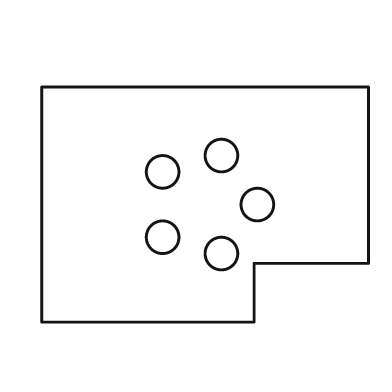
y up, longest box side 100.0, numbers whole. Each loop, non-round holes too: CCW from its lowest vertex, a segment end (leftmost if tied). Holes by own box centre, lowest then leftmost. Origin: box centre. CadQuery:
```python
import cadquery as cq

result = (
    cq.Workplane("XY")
    .moveTo(-50.0, -36.0)
    .lineTo(15.0, -36.0)
    .lineTo(15.0, -18.0)
    .lineTo(50.0, -18.0)
    .lineTo(50.0, 36.0)
    .lineTo(-50.0, 36.0)
    .close()
    .moveTo(5.0, -15.0)
    .circle(5.0)
    .moveTo(-13.0, -10.0)
    .circle(5.0)
    .moveTo(16.0, 0.0)
    .circle(5.0)
    .moveTo(-13.0, 10.0)
    .circle(5.0)
    .moveTo(5.0, 15.0)
    .circle(5.0)
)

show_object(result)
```